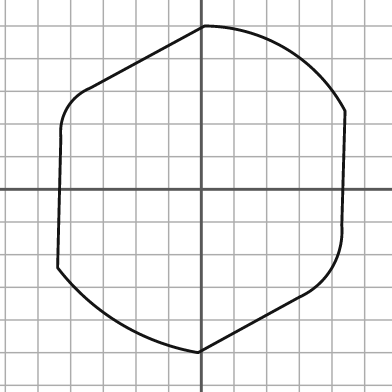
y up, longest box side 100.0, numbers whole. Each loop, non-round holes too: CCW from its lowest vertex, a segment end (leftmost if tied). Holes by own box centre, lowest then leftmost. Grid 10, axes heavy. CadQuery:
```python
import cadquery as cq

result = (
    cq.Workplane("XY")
    .moveTo(-1.0, -50.0)
    .lineTo(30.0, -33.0)
    .threePointArc((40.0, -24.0), (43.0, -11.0))
    .lineTo(44.0, 24.0)
    .threePointArc((26.0, 43.0), (1.0, 50.0))
    .lineTo(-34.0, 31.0)
    .threePointArc((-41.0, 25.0), (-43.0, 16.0))
    .lineTo(-44.0, -24.0)
    .threePointArc((-25.0, -41.0), (-1.0, -50.0))
    .close()
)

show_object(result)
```